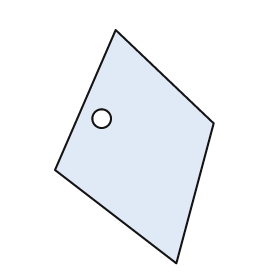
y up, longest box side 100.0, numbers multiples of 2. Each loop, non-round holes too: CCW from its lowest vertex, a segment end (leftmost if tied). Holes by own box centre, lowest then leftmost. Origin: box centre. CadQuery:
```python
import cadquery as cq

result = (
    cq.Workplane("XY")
    .moveTo(18.0, -50.0)
    .lineTo(34.0, 10.0)
    .lineTo(-8.0, 50.0)
    .lineTo(-34.0, -10.0)
    .close()
    .moveTo(-14.0, 12.0)
    .circle(4.0)
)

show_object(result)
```